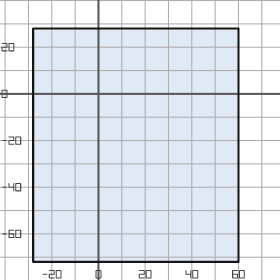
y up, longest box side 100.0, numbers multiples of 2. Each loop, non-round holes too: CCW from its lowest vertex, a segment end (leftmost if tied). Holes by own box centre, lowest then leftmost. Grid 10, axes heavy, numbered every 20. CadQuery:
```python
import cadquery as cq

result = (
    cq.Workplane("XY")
    .moveTo(-28.0, -72.0)
    .lineTo(60.0, -72.0)
    .lineTo(60.0, 28.0)
    .lineTo(-28.0, 28.0)
    .close()
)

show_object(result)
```